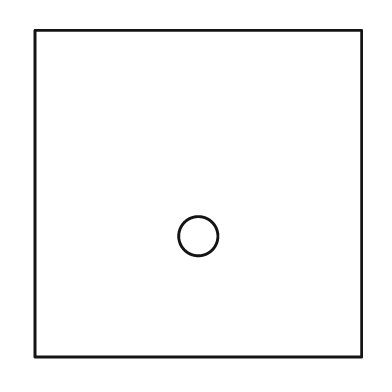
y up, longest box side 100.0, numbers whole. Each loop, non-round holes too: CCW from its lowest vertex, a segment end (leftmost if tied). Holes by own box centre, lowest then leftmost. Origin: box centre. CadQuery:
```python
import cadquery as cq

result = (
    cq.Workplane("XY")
    .moveTo(-50.0, -50.0)
    .lineTo(50.0, -50.0)
    .lineTo(50.0, 50.0)
    .lineTo(-50.0, 50.0)
    .close()
    .moveTo(0.0, -13.0)
    .circle(6.0)
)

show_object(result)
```